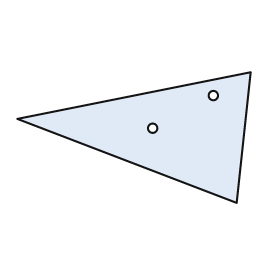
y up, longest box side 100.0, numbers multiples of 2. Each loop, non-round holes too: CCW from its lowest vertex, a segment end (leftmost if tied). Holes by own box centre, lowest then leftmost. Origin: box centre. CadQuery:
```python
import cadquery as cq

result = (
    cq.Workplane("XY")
    .moveTo(44.0, -28.0)
    .lineTo(50.0, 28.0)
    .lineTo(-50.0, 8.0)
    .close()
    .moveTo(8.0, 4.0)
    .circle(2.0)
    .moveTo(34.0, 18.0)
    .circle(2.0)
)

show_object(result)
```